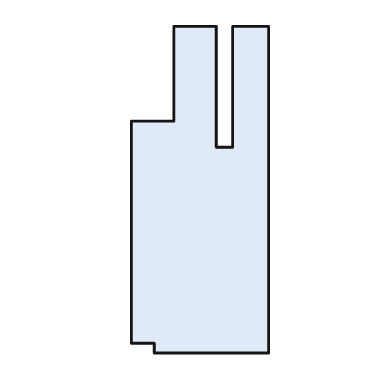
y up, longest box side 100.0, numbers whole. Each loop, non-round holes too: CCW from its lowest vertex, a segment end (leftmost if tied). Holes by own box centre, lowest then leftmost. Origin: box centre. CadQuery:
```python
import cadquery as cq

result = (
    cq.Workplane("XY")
    .moveTo(-14.0, -50.0)
    .lineTo(21.0, -50.0)
    .lineTo(21.0, 50.0)
    .lineTo(10.0, 50.0)
    .lineTo(10.0, 13.0)
    .lineTo(5.0, 13.0)
    .lineTo(5.0, 50.0)
    .lineTo(-8.0, 50.0)
    .lineTo(-8.0, 21.0)
    .lineTo(-21.0, 21.0)
    .lineTo(-21.0, -47.0)
    .lineTo(-14.0, -47.0)
    .close()
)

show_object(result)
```